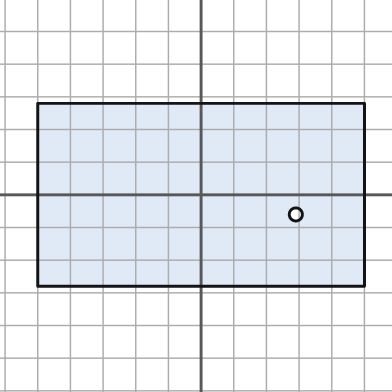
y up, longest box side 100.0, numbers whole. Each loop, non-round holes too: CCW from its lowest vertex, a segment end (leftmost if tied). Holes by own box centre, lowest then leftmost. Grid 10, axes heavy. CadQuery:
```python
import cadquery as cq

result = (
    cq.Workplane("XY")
    .moveTo(-50.0, -28.0)
    .lineTo(50.0, -28.0)
    .lineTo(50.0, 28.0)
    .lineTo(-50.0, 28.0)
    .close()
    .moveTo(29.0, -6.0)
    .circle(2.0)
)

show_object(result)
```